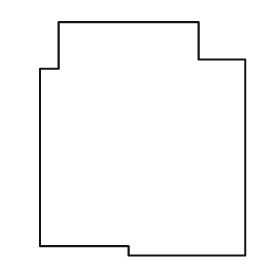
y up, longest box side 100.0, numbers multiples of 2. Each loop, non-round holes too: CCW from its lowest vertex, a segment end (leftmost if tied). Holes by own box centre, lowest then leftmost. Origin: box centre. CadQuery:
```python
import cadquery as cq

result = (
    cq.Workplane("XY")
    .moveTo(-6.0, -50.0)
    .lineTo(44.0, -50.0)
    .lineTo(44.0, 34.0)
    .lineTo(24.0, 34.0)
    .lineTo(24.0, 50.0)
    .lineTo(-36.0, 50.0)
    .lineTo(-36.0, 30.0)
    .lineTo(-44.0, 30.0)
    .lineTo(-44.0, -46.0)
    .lineTo(-6.0, -46.0)
    .close()
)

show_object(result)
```